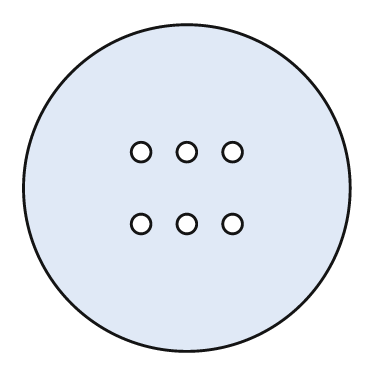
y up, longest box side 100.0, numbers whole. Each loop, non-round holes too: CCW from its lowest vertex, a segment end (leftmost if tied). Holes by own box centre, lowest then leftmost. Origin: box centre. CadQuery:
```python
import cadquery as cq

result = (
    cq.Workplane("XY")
    .moveTo(0.0, 0.0)
    .circle(50.0)
    .moveTo(-14.0, -11.0)
    .circle(3.0)
    .moveTo(0.0, -11.0)
    .circle(3.0)
    .moveTo(14.0, -11.0)
    .circle(3.0)
    .moveTo(-14.0, 11.0)
    .circle(3.0)
    .moveTo(0.0, 11.0)
    .circle(3.0)
    .moveTo(14.0, 11.0)
    .circle(3.0)
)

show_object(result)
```